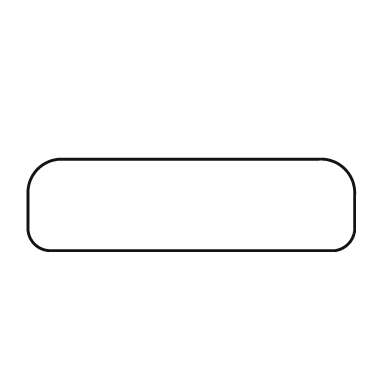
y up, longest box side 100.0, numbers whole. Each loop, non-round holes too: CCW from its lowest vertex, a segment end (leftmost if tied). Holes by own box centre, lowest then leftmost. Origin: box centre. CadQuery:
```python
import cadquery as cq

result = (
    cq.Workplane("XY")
    .moveTo(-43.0, -14.0)
    .lineTo(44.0, -14.0)
    .threePointArc((48.0, -12.0), (50.0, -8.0))
    .lineTo(50.0, 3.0)
    .threePointArc((47.0, 11.0), (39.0, 14.0))
    .lineTo(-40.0, 14.0)
    .threePointArc((-47.0, 11.0), (-50.0, 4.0))
    .lineTo(-50.0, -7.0)
    .threePointArc((-48.0, -12.0), (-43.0, -14.0))
    .close()
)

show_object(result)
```